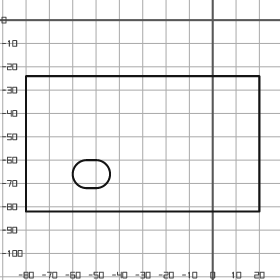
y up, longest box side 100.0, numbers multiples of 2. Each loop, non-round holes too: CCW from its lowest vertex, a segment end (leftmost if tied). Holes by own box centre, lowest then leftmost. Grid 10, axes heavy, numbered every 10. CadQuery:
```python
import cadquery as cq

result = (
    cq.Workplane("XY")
    .moveTo(-80.0, -82.0)
    .lineTo(20.0, -82.0)
    .lineTo(20.0, -24.0)
    .lineTo(-80.0, -24.0)
    .close()
    .moveTo(-54.0, -72.0)
    .lineTo(-50.0, -72.0)
    .threePointArc((-44.0, -66.0), (-50.0, -60.0))
    .lineTo(-54.0, -60.0)
    .threePointArc((-60.0, -66.0), (-54.0, -72.0))
    .close()
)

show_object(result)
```